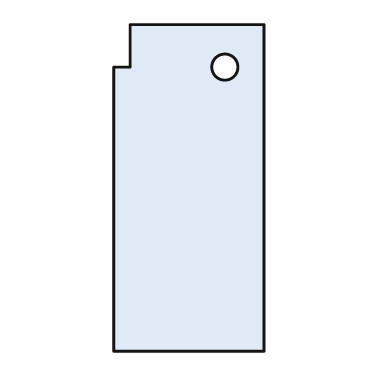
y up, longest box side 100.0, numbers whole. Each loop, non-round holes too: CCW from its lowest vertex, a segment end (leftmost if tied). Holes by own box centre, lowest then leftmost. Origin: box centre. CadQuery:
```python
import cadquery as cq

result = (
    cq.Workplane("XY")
    .moveTo(-23.0, -50.0)
    .lineTo(23.0, -50.0)
    .lineTo(23.0, 50.0)
    .lineTo(-18.0, 50.0)
    .lineTo(-18.0, 37.0)
    .lineTo(-23.0, 37.0)
    .close()
    .moveTo(11.0, 37.0)
    .circle(4.0)
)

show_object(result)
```